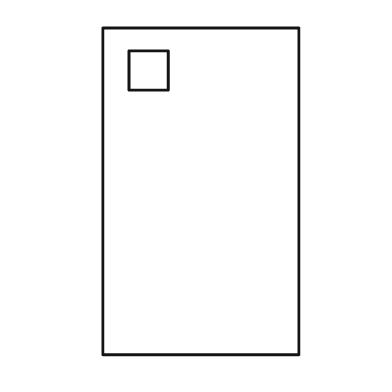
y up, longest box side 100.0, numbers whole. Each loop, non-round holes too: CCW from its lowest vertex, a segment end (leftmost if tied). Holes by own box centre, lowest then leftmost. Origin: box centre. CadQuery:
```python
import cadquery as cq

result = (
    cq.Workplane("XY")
    .moveTo(-30.0, -50.0)
    .lineTo(30.0, -50.0)
    .lineTo(30.0, 50.0)
    .lineTo(-30.0, 50.0)
    .close()
    .moveTo(-22.0, 31.0)
    .lineTo(-10.0, 31.0)
    .lineTo(-10.0, 43.0)
    .lineTo(-22.0, 43.0)
    .close()
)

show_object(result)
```